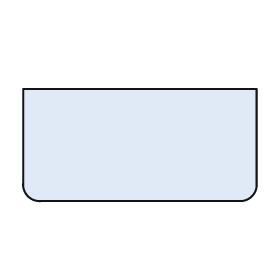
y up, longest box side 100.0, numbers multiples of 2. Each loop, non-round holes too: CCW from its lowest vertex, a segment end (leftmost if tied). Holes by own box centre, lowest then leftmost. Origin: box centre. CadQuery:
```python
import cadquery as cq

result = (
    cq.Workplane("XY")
    .moveTo(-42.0, -24.0)
    .lineTo(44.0, -24.0)
    .threePointArc((48.0, -22.0), (50.0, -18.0))
    .lineTo(50.0, 24.0)
    .lineTo(-50.0, 24.0)
    .lineTo(-50.0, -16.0)
    .threePointArc((-48.0, -22.0), (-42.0, -24.0))
    .close()
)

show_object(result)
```